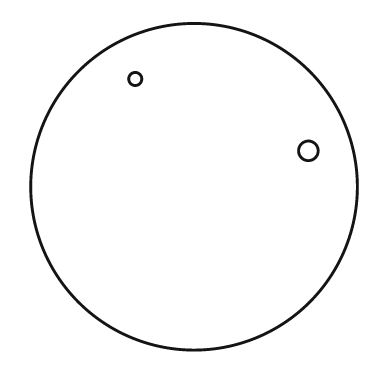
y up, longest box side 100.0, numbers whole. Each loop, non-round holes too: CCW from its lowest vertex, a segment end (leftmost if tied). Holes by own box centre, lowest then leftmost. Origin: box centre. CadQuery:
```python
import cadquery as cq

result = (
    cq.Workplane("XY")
    .moveTo(0.0, 0.0)
    .circle(50.0)
    .moveTo(35.0, 11.0)
    .circle(3.0)
    .moveTo(-18.0, 33.0)
    .circle(2.0)
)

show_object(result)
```